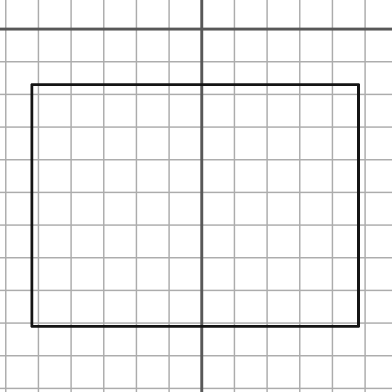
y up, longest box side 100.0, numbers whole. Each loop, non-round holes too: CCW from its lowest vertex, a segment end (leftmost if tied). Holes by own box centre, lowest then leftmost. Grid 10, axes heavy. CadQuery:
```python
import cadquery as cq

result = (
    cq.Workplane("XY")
    .moveTo(-52.0, -91.0)
    .lineTo(48.0, -91.0)
    .lineTo(48.0, -17.0)
    .lineTo(-52.0, -17.0)
    .close()
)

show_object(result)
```